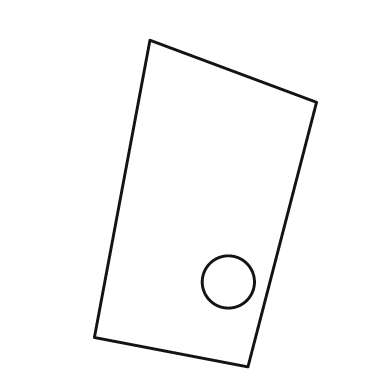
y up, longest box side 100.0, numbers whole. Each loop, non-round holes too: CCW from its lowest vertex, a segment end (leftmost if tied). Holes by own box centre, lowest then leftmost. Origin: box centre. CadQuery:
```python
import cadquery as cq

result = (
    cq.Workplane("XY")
    .moveTo(13.0, -50.0)
    .lineTo(34.0, 31.0)
    .lineTo(-17.0, 50.0)
    .lineTo(-34.0, -41.0)
    .close()
    .moveTo(7.0, -24.0)
    .circle(8.0)
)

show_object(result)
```